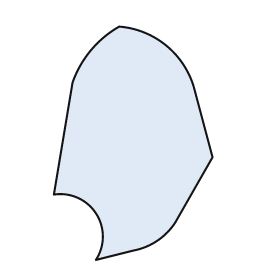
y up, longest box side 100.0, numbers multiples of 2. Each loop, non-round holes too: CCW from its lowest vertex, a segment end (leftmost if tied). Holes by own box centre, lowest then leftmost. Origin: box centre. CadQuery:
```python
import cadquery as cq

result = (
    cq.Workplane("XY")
    .moveTo(-16.0, -50.0)
    .lineTo(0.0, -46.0)
    .threePointArc((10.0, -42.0), (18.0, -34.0))
    .lineTo(34.0, -6.0)
    .lineTo(26.0, 24.0)
    .threePointArc((14.0, 42.0), (-6.0, 50.0))
    .threePointArc((-18.0, 40.0), (-26.0, 26.0))
    .lineTo(-34.0, -22.0)
    .threePointArc((-16.0, -30.0), (-16.0, -50.0))
    .close()
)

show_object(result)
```